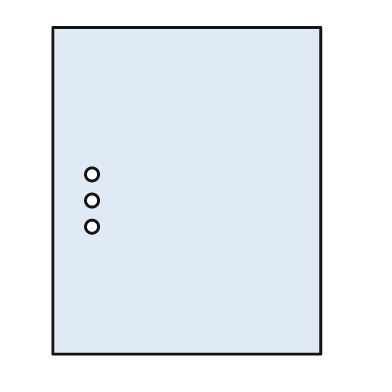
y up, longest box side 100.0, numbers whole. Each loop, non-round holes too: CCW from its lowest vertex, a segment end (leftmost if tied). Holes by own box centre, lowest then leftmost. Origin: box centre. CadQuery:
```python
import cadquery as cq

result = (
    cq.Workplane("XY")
    .moveTo(-41.0, -50.0)
    .lineTo(41.0, -50.0)
    .lineTo(41.0, 50.0)
    .lineTo(-41.0, 50.0)
    .close()
    .moveTo(-29.0, -11.0)
    .circle(2.0)
    .moveTo(-29.0, -3.0)
    .circle(2.0)
    .moveTo(-29.0, 5.0)
    .circle(2.0)
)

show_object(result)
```